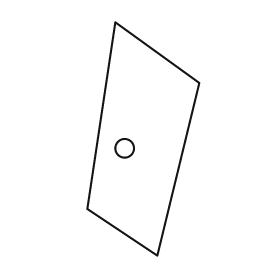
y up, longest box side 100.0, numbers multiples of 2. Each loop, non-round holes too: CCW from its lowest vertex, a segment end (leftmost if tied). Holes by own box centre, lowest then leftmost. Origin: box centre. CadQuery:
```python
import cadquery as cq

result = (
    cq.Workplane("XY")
    .moveTo(6.0, -50.0)
    .lineTo(24.0, 24.0)
    .lineTo(-12.0, 50.0)
    .lineTo(-24.0, -30.0)
    .close()
    .moveTo(-8.0, -4.0)
    .circle(4.0)
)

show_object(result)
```